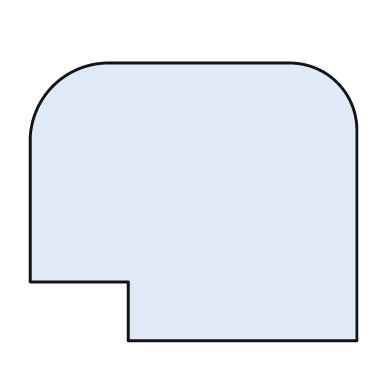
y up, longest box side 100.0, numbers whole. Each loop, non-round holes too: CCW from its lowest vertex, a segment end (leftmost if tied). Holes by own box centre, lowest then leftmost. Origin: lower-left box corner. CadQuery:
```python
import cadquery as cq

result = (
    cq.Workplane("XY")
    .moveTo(30.0, 0.0)
    .lineTo(100.0, 0.0)
    .lineTo(100.0, 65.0)
    .threePointArc((94.0, 79.0), (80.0, 85.0))
    .lineTo(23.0, 85.0)
    .threePointArc((7.0, 78.0), (0.0, 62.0))
    .lineTo(0.0, 18.0)
    .lineTo(30.0, 18.0)
    .close()
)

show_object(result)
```